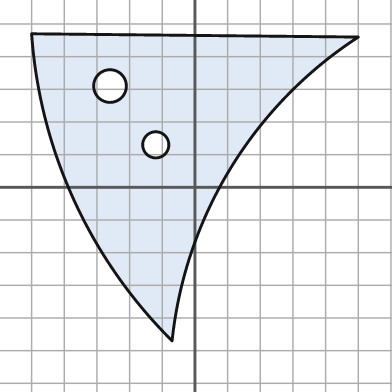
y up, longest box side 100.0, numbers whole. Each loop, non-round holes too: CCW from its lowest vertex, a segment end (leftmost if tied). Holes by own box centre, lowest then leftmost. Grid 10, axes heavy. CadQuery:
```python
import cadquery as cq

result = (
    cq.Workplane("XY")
    .moveTo(-7.0, -47.0)
    .threePointArc((11.0, 6.0), (50.0, 46.0))
    .lineTo(-50.0, 47.0)
    .threePointArc((-37.0, -4.0), (-7.0, -47.0))
    .close()
    .moveTo(-12.0, 13.0)
    .circle(4.0)
    .moveTo(-26.0, 31.0)
    .circle(5.0)
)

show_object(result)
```